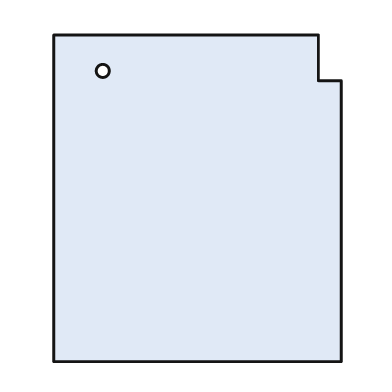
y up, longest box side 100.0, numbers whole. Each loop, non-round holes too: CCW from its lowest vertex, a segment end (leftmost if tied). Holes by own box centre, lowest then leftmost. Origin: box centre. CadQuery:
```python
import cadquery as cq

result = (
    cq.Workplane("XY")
    .moveTo(-44.0, -50.0)
    .lineTo(44.0, -50.0)
    .lineTo(44.0, 36.0)
    .lineTo(37.0, 36.0)
    .lineTo(37.0, 50.0)
    .lineTo(-44.0, 50.0)
    .close()
    .moveTo(-29.0, 39.0)
    .circle(2.0)
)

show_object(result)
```